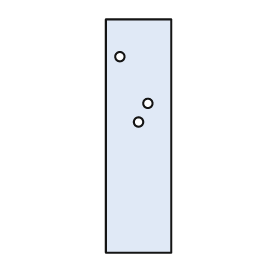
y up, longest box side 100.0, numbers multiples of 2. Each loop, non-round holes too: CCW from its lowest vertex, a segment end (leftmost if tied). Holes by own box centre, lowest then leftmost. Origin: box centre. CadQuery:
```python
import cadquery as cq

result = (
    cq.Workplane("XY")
    .moveTo(-14.0, -50.0)
    .lineTo(14.0, -50.0)
    .lineTo(14.0, 50.0)
    .lineTo(-14.0, 50.0)
    .close()
    .moveTo(0.0, 6.0)
    .circle(2.0)
    .moveTo(4.0, 14.0)
    .circle(2.0)
    .moveTo(-8.0, 34.0)
    .circle(2.0)
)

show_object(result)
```